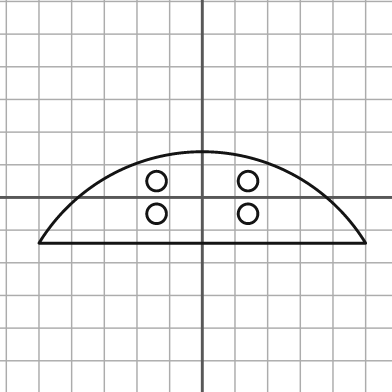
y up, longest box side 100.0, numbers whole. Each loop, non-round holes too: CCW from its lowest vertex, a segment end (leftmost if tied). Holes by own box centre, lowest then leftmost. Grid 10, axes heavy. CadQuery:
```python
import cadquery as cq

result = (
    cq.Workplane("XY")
    .moveTo(-50.0, -14.0)
    .lineTo(50.0, -14.0)
    .threePointArc((0.0, 14.0), (-50.0, -14.0))
    .close()
    .moveTo(-14.0, -5.0)
    .circle(3.0)
    .moveTo(14.0, -5.0)
    .circle(3.0)
    .moveTo(-14.0, 5.0)
    .circle(3.0)
    .moveTo(14.0, 5.0)
    .circle(3.0)
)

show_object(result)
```